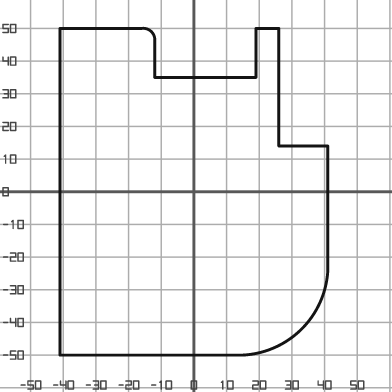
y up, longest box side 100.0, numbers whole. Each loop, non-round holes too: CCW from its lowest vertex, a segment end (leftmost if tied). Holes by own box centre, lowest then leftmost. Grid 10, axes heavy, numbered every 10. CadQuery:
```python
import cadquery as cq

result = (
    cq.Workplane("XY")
    .moveTo(-41.0, -50.0)
    .lineTo(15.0, -50.0)
    .threePointArc((33.0, -42.0), (41.0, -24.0))
    .lineTo(41.0, 14.0)
    .lineTo(26.0, 14.0)
    .lineTo(26.0, 50.0)
    .lineTo(19.0, 50.0)
    .lineTo(19.0, 35.0)
    .lineTo(-12.0, 35.0)
    .lineTo(-12.0, 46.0)
    .threePointArc((-13.0, 49.0), (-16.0, 50.0))
    .lineTo(-41.0, 50.0)
    .close()
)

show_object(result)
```